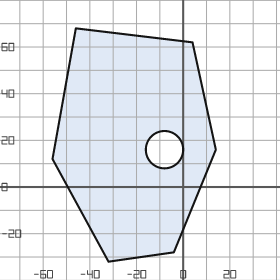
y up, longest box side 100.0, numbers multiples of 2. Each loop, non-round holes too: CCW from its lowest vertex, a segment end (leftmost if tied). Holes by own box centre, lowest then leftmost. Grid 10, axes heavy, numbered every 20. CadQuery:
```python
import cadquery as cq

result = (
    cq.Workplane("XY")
    .moveTo(-32.0, -32.0)
    .lineTo(-4.0, -28.0)
    .lineTo(14.0, 16.0)
    .lineTo(4.0, 62.0)
    .lineTo(-46.0, 68.0)
    .lineTo(-56.0, 12.0)
    .close()
    .moveTo(-8.0, 16.0)
    .circle(8.0)
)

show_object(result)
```